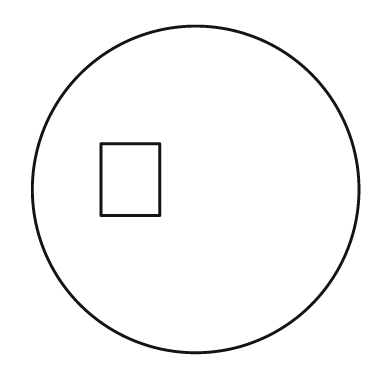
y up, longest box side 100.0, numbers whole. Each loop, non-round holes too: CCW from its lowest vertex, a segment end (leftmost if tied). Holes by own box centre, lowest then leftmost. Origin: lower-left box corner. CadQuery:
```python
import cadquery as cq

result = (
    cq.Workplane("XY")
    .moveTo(50.0, 50.0)
    .circle(50.0)
    .moveTo(21.0, 42.0)
    .lineTo(39.0, 42.0)
    .lineTo(39.0, 64.0)
    .lineTo(21.0, 64.0)
    .close()
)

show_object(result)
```